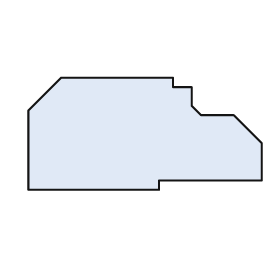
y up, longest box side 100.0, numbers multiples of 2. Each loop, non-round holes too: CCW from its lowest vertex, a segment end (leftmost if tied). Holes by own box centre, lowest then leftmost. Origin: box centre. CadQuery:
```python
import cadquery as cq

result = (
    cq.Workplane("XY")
    .moveTo(-50.0, -24.0)
    .lineTo(6.0, -24.0)
    .lineTo(6.0, -20.0)
    .lineTo(50.0, -20.0)
    .lineTo(50.0, -4.0)
    .lineTo(38.0, 8.0)
    .lineTo(24.0, 8.0)
    .lineTo(20.0, 12.0)
    .lineTo(20.0, 20.0)
    .lineTo(12.0, 20.0)
    .lineTo(12.0, 24.0)
    .lineTo(-36.0, 24.0)
    .lineTo(-50.0, 10.0)
    .close()
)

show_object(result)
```